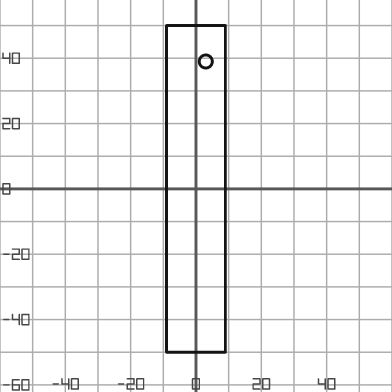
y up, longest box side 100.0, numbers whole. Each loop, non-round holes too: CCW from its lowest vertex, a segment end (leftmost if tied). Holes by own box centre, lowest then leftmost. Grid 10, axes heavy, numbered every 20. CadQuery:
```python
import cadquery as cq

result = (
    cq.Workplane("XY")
    .moveTo(-9.0, -50.0)
    .lineTo(9.0, -50.0)
    .lineTo(9.0, 50.0)
    .lineTo(-9.0, 50.0)
    .close()
    .moveTo(3.0, 39.0)
    .circle(2.0)
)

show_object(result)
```